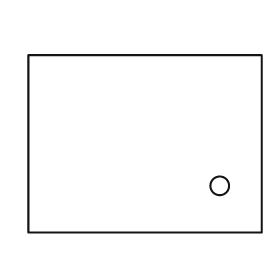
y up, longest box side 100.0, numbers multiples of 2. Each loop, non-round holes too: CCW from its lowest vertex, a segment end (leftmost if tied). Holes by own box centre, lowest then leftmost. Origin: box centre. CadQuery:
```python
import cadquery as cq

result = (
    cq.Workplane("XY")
    .moveTo(-50.0, -38.0)
    .lineTo(50.0, -38.0)
    .lineTo(50.0, 38.0)
    .lineTo(-50.0, 38.0)
    .close()
    .moveTo(32.0, -18.0)
    .circle(4.0)
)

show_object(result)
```